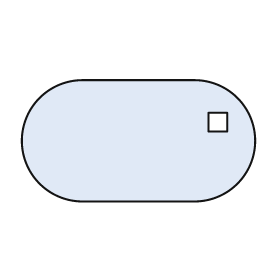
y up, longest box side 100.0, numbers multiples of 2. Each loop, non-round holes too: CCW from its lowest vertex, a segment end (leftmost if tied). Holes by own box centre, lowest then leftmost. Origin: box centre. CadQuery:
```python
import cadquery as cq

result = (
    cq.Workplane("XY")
    .moveTo(-24.0, -26.0)
    .lineTo(24.0, -26.0)
    .threePointArc((50.0, 0.0), (24.0, 26.0))
    .lineTo(-24.0, 26.0)
    .threePointArc((-50.0, 0.0), (-24.0, -26.0))
    .close()
    .moveTo(30.0, 4.0)
    .lineTo(38.0, 4.0)
    .lineTo(38.0, 12.0)
    .lineTo(30.0, 12.0)
    .close()
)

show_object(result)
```